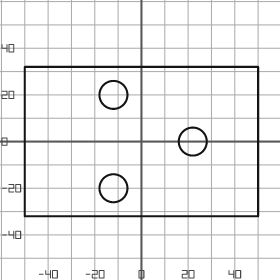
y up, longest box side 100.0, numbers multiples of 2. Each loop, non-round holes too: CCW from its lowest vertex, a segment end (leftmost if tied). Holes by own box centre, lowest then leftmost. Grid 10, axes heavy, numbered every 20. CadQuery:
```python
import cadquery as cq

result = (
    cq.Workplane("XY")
    .moveTo(-50.0, -32.0)
    .lineTo(50.0, -32.0)
    .lineTo(50.0, 32.0)
    .lineTo(-50.0, 32.0)
    .close()
    .moveTo(-12.0, -20.0)
    .circle(6.0)
    .moveTo(22.0, 0.0)
    .circle(6.0)
    .moveTo(-12.0, 20.0)
    .circle(6.0)
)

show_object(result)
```